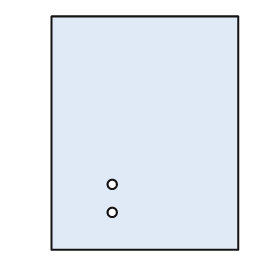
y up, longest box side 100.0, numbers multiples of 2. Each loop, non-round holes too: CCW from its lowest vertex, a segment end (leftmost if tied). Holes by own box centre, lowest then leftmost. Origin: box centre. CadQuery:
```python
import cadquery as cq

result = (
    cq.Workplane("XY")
    .moveTo(-40.0, -50.0)
    .lineTo(40.0, -50.0)
    .lineTo(40.0, 50.0)
    .lineTo(-40.0, 50.0)
    .close()
    .moveTo(-14.0, -34.0)
    .circle(2.0)
    .moveTo(-14.0, -22.0)
    .circle(2.0)
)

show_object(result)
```